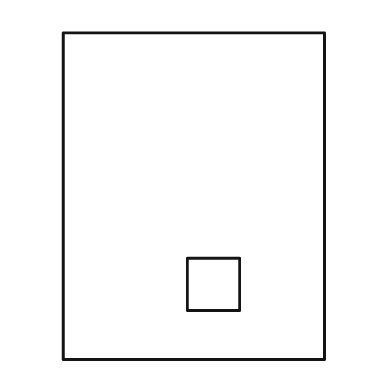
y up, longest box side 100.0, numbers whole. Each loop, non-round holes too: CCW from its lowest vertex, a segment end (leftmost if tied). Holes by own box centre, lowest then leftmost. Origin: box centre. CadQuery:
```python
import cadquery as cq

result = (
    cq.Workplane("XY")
    .moveTo(-40.0, -50.0)
    .lineTo(40.0, -50.0)
    .lineTo(40.0, 50.0)
    .lineTo(-40.0, 50.0)
    .close()
    .moveTo(-2.0, -35.0)
    .lineTo(14.0, -35.0)
    .lineTo(14.0, -19.0)
    .lineTo(-2.0, -19.0)
    .close()
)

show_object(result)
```